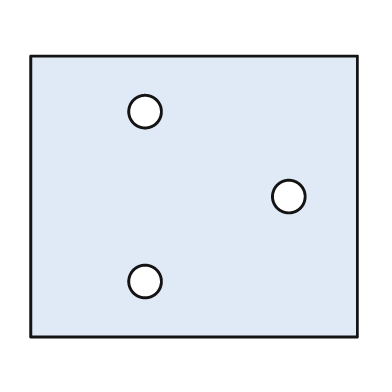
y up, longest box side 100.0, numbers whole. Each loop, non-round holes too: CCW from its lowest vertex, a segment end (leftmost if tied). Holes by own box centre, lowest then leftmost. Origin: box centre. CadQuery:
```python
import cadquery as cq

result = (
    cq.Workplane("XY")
    .moveTo(-50.0, -43.0)
    .lineTo(50.0, -43.0)
    .lineTo(50.0, 43.0)
    .lineTo(-50.0, 43.0)
    .close()
    .moveTo(-15.0, -26.0)
    .circle(5.0)
    .moveTo(29.0, 0.0)
    .circle(5.0)
    .moveTo(-15.0, 26.0)
    .circle(5.0)
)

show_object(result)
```